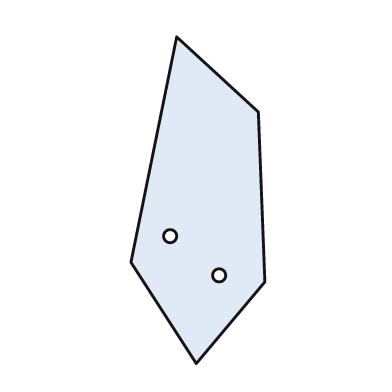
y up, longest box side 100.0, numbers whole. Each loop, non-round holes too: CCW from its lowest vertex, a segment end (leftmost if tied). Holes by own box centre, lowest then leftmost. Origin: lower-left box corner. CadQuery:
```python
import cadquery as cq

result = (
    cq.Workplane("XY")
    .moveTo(20.0, 0.0)
    .lineTo(41.0, 25.0)
    .lineTo(39.0, 77.0)
    .lineTo(14.0, 100.0)
    .lineTo(0.0, 31.0)
    .close()
    .moveTo(27.0, 27.0)
    .circle(2.0)
    .moveTo(12.0, 39.0)
    .circle(2.0)
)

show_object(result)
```